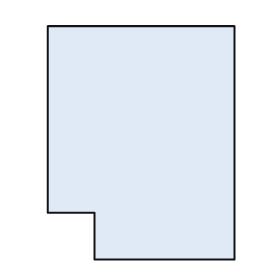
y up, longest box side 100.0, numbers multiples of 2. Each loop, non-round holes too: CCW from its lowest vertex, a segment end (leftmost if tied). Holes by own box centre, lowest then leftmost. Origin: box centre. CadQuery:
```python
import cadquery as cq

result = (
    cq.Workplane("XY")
    .moveTo(-20.0, -50.0)
    .lineTo(40.0, -50.0)
    .lineTo(40.0, 50.0)
    .lineTo(-40.0, 50.0)
    .lineTo(-40.0, -30.0)
    .lineTo(-20.0, -30.0)
    .close()
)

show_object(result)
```